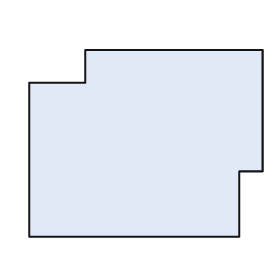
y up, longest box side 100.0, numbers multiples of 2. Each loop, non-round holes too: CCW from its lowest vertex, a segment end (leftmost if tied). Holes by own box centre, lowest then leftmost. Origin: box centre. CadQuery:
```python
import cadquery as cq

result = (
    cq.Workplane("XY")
    .moveTo(-50.0, -40.0)
    .lineTo(40.0, -40.0)
    .lineTo(40.0, -12.0)
    .lineTo(50.0, -12.0)
    .lineTo(50.0, 40.0)
    .lineTo(-26.0, 40.0)
    .lineTo(-26.0, 26.0)
    .lineTo(-50.0, 26.0)
    .close()
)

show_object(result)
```